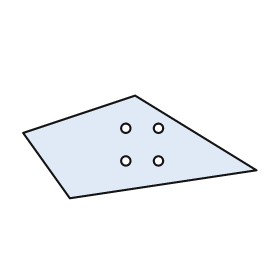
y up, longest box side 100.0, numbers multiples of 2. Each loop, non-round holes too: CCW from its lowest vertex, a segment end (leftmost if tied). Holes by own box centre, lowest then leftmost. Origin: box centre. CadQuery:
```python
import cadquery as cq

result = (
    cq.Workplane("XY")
    .moveTo(-30.0, -22.0)
    .lineTo(50.0, -10.0)
    .lineTo(-2.0, 22.0)
    .lineTo(-50.0, 6.0)
    .close()
    .moveTo(-6.0, -6.0)
    .circle(2.0)
    .moveTo(8.0, -6.0)
    .circle(2.0)
    .moveTo(-6.0, 8.0)
    .circle(2.0)
    .moveTo(8.0, 8.0)
    .circle(2.0)
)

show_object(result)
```